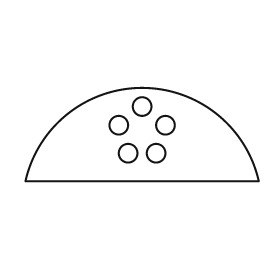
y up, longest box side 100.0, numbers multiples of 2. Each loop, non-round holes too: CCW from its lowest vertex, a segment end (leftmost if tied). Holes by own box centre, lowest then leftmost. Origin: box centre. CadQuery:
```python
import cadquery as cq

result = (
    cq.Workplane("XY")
    .moveTo(-50.0, -20.0)
    .lineTo(50.0, -20.0)
    .threePointArc((0.0, 20.0), (-50.0, -20.0))
    .close()
    .moveTo(-6.0, -8.0)
    .circle(4.0)
    .moveTo(6.0, -8.0)
    .circle(4.0)
    .moveTo(-10.0, 4.0)
    .circle(4.0)
    .moveTo(10.0, 4.0)
    .circle(4.0)
    .moveTo(0.0, 12.0)
    .circle(4.0)
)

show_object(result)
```